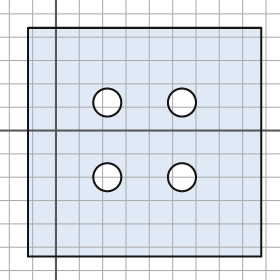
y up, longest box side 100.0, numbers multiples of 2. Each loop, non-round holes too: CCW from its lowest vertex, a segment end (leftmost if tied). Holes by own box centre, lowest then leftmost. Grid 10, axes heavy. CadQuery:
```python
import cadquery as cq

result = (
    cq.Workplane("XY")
    .moveTo(-12.0, -54.0)
    .lineTo(88.0, -54.0)
    .lineTo(88.0, 44.0)
    .lineTo(-12.0, 44.0)
    .close()
    .moveTo(22.0, -20.0)
    .circle(6.0)
    .moveTo(54.0, -20.0)
    .circle(6.0)
    .moveTo(22.0, 12.0)
    .circle(6.0)
    .moveTo(54.0, 12.0)
    .circle(6.0)
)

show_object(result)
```